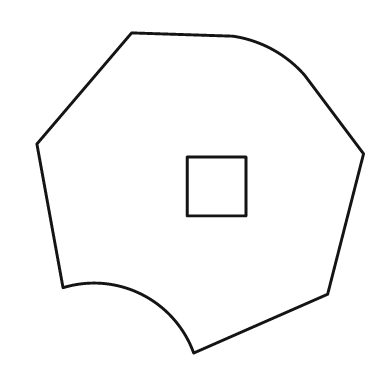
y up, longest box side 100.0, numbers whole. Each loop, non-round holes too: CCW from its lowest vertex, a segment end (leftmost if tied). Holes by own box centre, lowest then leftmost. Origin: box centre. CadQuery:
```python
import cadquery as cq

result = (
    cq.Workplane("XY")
    .moveTo(-2.0, -49.0)
    .lineTo(39.0, -31.0)
    .lineTo(50.0, 12.0)
    .lineTo(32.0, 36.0)
    .threePointArc((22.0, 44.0), (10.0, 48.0))
    .lineTo(-21.0, 49.0)
    .lineTo(-50.0, 15.0)
    .lineTo(-42.0, -29.0)
    .threePointArc((-18.0, -31.0), (-2.0, -49.0))
    .close()
    .moveTo(-4.0, -7.0)
    .lineTo(14.0, -7.0)
    .lineTo(14.0, 11.0)
    .lineTo(-4.0, 11.0)
    .close()
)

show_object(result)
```